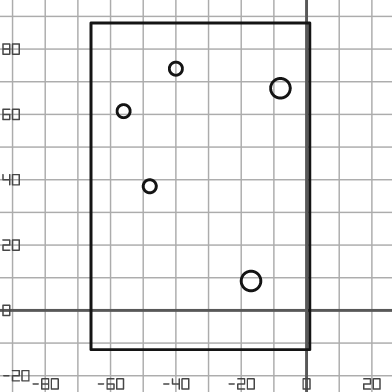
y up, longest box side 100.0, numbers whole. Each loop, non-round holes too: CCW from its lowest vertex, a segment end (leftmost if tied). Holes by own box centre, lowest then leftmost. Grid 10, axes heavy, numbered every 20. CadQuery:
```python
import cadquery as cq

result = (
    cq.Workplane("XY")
    .moveTo(-66.0, -12.0)
    .lineTo(1.0, -12.0)
    .lineTo(1.0, 88.0)
    .lineTo(-66.0, 88.0)
    .close()
    .moveTo(-17.0, 9.0)
    .circle(3.0)
    .moveTo(-48.0, 38.0)
    .circle(2.0)
    .moveTo(-56.0, 61.0)
    .circle(2.0)
    .moveTo(-8.0, 68.0)
    .circle(3.0)
    .moveTo(-40.0, 74.0)
    .circle(2.0)
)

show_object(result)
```